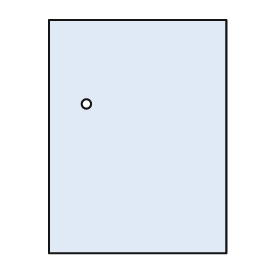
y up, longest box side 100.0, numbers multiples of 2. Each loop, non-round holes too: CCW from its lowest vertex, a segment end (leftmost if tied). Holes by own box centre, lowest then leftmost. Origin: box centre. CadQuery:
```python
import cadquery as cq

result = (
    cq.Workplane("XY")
    .moveTo(-38.0, -50.0)
    .lineTo(38.0, -50.0)
    .lineTo(38.0, 50.0)
    .lineTo(-38.0, 50.0)
    .close()
    .moveTo(-22.0, 14.0)
    .circle(2.0)
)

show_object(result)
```